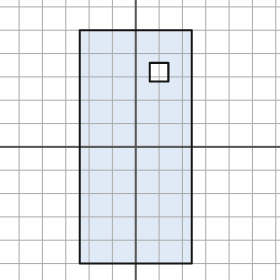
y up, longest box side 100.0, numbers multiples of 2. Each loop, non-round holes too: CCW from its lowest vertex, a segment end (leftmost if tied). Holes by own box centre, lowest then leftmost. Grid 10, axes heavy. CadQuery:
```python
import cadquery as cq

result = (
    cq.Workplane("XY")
    .moveTo(-24.0, -50.0)
    .lineTo(24.0, -50.0)
    .lineTo(24.0, 50.0)
    .lineTo(-24.0, 50.0)
    .close()
    .moveTo(6.0, 28.0)
    .lineTo(14.0, 28.0)
    .lineTo(14.0, 36.0)
    .lineTo(6.0, 36.0)
    .close()
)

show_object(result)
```